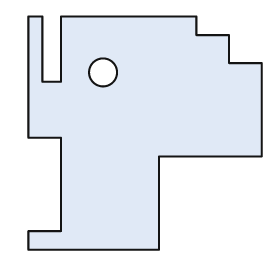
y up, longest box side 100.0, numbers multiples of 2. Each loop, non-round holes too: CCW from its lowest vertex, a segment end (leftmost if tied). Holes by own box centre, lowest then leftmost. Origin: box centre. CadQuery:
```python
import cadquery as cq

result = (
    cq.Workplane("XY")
    .moveTo(-50.0, -50.0)
    .lineTo(6.0, -50.0)
    .lineTo(6.0, -10.0)
    .lineTo(50.0, -10.0)
    .lineTo(50.0, 30.0)
    .lineTo(36.0, 30.0)
    .lineTo(36.0, 42.0)
    .lineTo(22.0, 42.0)
    .lineTo(22.0, 50.0)
    .lineTo(-36.0, 50.0)
    .lineTo(-36.0, 22.0)
    .lineTo(-44.0, 22.0)
    .lineTo(-44.0, 50.0)
    .lineTo(-50.0, 50.0)
    .lineTo(-50.0, -2.0)
    .lineTo(-36.0, -2.0)
    .lineTo(-36.0, -42.0)
    .lineTo(-50.0, -42.0)
    .close()
    .moveTo(-18.0, 26.0)
    .circle(6.0)
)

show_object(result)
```